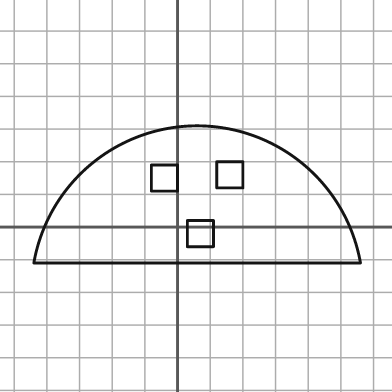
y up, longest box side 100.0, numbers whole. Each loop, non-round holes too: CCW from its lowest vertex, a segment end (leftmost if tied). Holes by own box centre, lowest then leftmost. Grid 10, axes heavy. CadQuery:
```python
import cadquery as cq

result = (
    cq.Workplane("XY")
    .moveTo(-44.0, -11.0)
    .lineTo(56.0, -11.0)
    .threePointArc((6.0, 31.0), (-44.0, -11.0))
    .close()
    .moveTo(3.0, -6.0)
    .lineTo(11.0, -6.0)
    .lineTo(11.0, 2.0)
    .lineTo(3.0, 2.0)
    .close()
    .moveTo(-8.0, 11.0)
    .lineTo(0.0, 11.0)
    .lineTo(0.0, 19.0)
    .lineTo(-8.0, 19.0)
    .close()
    .moveTo(12.0, 12.0)
    .lineTo(20.0, 12.0)
    .lineTo(20.0, 20.0)
    .lineTo(12.0, 20.0)
    .close()
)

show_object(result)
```